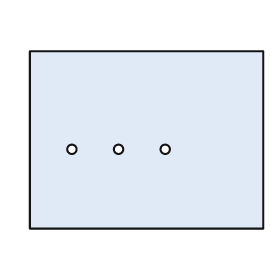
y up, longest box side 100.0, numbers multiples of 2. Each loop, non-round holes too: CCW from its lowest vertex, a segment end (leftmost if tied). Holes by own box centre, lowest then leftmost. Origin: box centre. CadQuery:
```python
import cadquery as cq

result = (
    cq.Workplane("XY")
    .moveTo(-50.0, -38.0)
    .lineTo(50.0, -38.0)
    .lineTo(50.0, 38.0)
    .lineTo(-50.0, 38.0)
    .close()
    .moveTo(-32.0, -4.0)
    .circle(2.0)
    .moveTo(-12.0, -4.0)
    .circle(2.0)
    .moveTo(8.0, -4.0)
    .circle(2.0)
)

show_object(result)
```